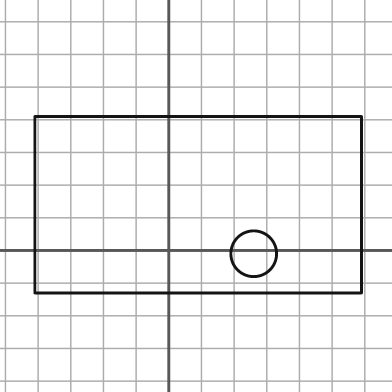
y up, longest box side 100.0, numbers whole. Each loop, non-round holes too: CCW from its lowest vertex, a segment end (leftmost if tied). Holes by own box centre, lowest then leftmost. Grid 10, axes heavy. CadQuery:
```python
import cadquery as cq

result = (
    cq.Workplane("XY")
    .moveTo(-41.0, -13.0)
    .lineTo(59.0, -13.0)
    .lineTo(59.0, 41.0)
    .lineTo(-41.0, 41.0)
    .close()
    .moveTo(26.0, -1.0)
    .circle(7.0)
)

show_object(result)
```